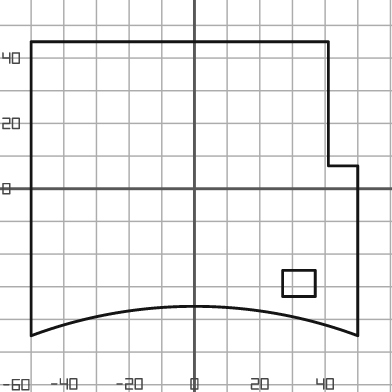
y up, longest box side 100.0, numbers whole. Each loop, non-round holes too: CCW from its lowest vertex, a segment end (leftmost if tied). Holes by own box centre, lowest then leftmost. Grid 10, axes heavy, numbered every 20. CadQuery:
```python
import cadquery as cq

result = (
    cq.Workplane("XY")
    .moveTo(-50.0, -45.0)
    .threePointArc((0.0, -36.0), (50.0, -45.0))
    .lineTo(50.0, 7.0)
    .lineTo(41.0, 7.0)
    .lineTo(41.0, 45.0)
    .lineTo(-50.0, 45.0)
    .close()
    .moveTo(27.0, -33.0)
    .lineTo(37.0, -33.0)
    .lineTo(37.0, -25.0)
    .lineTo(27.0, -25.0)
    .close()
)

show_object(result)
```